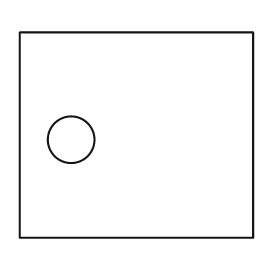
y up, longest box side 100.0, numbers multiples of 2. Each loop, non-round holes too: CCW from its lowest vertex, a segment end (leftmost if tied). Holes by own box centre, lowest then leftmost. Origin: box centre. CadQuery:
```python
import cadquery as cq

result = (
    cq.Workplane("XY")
    .moveTo(-50.0, -44.0)
    .lineTo(50.0, -44.0)
    .lineTo(50.0, 44.0)
    .lineTo(-50.0, 44.0)
    .close()
    .moveTo(-28.0, -2.0)
    .circle(10.0)
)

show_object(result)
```